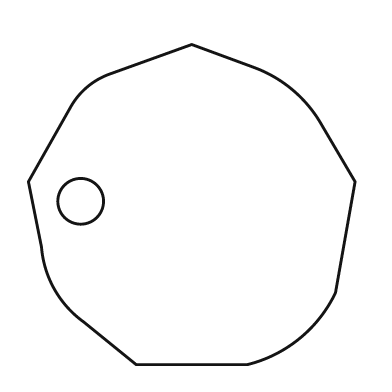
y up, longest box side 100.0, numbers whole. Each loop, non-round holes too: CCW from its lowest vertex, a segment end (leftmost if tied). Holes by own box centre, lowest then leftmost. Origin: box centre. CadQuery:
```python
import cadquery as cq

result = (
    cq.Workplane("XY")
    .moveTo(-17.0, -49.0)
    .lineTo(17.0, -49.0)
    .threePointArc((33.0, -41.0), (44.0, -27.0))
    .lineTo(50.0, 7.0)
    .lineTo(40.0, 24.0)
    .threePointArc((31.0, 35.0), (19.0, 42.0))
    .lineTo(0.0, 49.0)
    .lineTo(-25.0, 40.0)
    .threePointArc((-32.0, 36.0), (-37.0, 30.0))
    .lineTo(-50.0, 7.0)
    .lineTo(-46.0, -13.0)
    .threePointArc((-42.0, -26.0), (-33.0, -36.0))
    .close()
    .moveTo(-34.0, 1.0)
    .circle(7.0)
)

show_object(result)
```